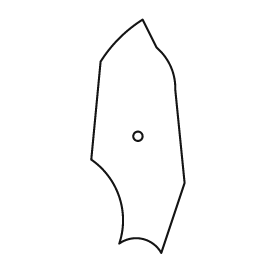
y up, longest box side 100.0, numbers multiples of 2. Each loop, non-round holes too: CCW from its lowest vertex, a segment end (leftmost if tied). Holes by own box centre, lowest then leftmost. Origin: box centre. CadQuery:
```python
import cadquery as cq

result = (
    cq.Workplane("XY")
    .moveTo(10.0, -50.0)
    .lineTo(20.0, -20.0)
    .lineTo(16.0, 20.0)
    .threePointArc((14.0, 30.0), (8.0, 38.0))
    .lineTo(2.0, 50.0)
    .threePointArc((-8.0, 42.0), (-16.0, 32.0))
    .lineTo(-20.0, -10.0)
    .threePointArc((-8.0, -26.0), (-8.0, -46.0))
    .threePointArc((2.0, -44.0), (10.0, -50.0))
    .close()
    .moveTo(0.0, 0.0)
    .circle(2.0)
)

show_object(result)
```